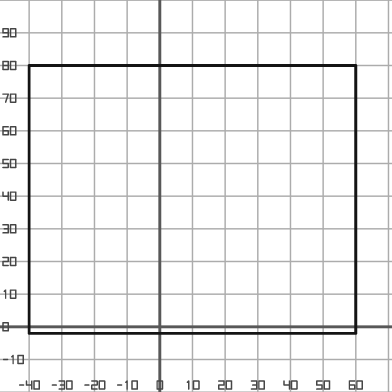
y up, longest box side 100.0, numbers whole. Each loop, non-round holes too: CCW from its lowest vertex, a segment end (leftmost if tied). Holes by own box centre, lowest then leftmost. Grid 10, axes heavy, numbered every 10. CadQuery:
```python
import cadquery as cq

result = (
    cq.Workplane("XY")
    .moveTo(-40.0, -2.0)
    .lineTo(60.0, -2.0)
    .lineTo(60.0, 80.0)
    .lineTo(-40.0, 80.0)
    .close()
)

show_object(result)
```